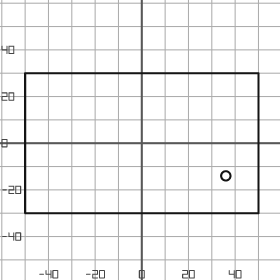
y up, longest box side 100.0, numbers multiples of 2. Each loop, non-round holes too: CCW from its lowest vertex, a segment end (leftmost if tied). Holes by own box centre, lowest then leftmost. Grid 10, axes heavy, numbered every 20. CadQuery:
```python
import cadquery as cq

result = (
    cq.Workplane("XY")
    .moveTo(-50.0, -30.0)
    .lineTo(50.0, -30.0)
    .lineTo(50.0, 30.0)
    .lineTo(-50.0, 30.0)
    .close()
    .moveTo(36.0, -14.0)
    .circle(2.0)
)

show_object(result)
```